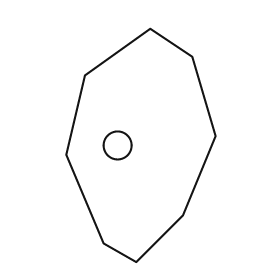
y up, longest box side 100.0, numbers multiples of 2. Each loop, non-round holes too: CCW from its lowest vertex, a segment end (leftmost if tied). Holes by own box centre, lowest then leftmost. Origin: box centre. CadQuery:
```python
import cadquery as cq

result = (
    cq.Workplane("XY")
    .moveTo(-2.0, -50.0)
    .lineTo(18.0, -30.0)
    .lineTo(32.0, 4.0)
    .lineTo(22.0, 38.0)
    .lineTo(4.0, 50.0)
    .lineTo(-24.0, 30.0)
    .lineTo(-32.0, -4.0)
    .lineTo(-16.0, -42.0)
    .close()
    .moveTo(-10.0, 0.0)
    .circle(6.0)
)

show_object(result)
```